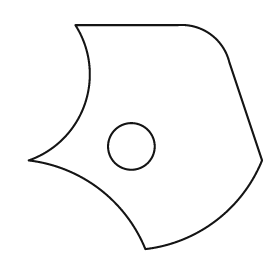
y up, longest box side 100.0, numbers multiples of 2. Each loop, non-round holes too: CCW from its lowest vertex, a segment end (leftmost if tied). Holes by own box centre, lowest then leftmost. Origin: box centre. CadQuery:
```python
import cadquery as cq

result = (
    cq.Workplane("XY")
    .moveTo(0.0, -48.0)
    .threePointArc((30.0, -36.0), (50.0, -10.0))
    .lineTo(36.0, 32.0)
    .threePointArc((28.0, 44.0), (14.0, 48.0))
    .lineTo(-30.0, 48.0)
    .threePointArc((-26.0, 14.0), (-50.0, -10.0))
    .threePointArc((-20.0, -22.0), (0.0, -48.0))
    .close()
    .moveTo(-6.0, -4.0)
    .circle(10.0)
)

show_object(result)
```